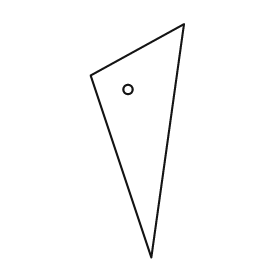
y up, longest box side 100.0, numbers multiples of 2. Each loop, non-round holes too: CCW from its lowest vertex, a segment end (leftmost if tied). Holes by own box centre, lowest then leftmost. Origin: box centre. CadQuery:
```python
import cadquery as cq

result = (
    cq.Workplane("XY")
    .moveTo(6.0, -50.0)
    .lineTo(20.0, 50.0)
    .lineTo(-20.0, 28.0)
    .close()
    .moveTo(-4.0, 22.0)
    .circle(2.0)
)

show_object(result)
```